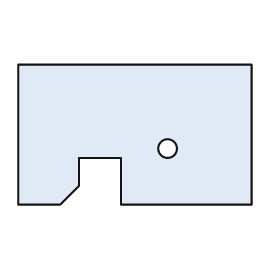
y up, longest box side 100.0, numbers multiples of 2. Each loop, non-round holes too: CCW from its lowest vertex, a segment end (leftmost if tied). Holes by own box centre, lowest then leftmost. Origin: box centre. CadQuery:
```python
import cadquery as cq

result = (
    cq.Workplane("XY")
    .moveTo(-50.0, -30.0)
    .lineTo(-32.0, -30.0)
    .lineTo(-24.0, -22.0)
    .lineTo(-24.0, -10.0)
    .lineTo(-6.0, -10.0)
    .lineTo(-6.0, -30.0)
    .lineTo(50.0, -30.0)
    .lineTo(50.0, 30.0)
    .lineTo(-50.0, 30.0)
    .close()
    .moveTo(14.0, -6.0)
    .circle(4.0)
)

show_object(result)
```